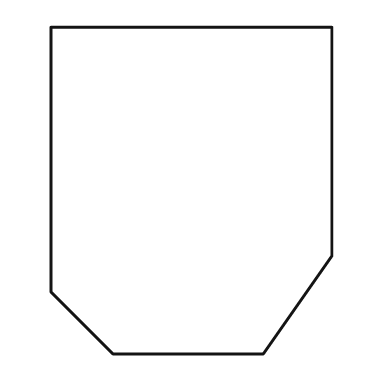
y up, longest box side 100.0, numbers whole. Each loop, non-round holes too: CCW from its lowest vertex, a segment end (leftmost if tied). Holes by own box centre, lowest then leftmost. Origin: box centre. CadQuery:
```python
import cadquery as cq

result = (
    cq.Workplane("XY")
    .moveTo(-24.0, -50.0)
    .lineTo(22.0, -50.0)
    .lineTo(43.0, -20.0)
    .lineTo(43.0, 50.0)
    .lineTo(-43.0, 50.0)
    .lineTo(-43.0, -31.0)
    .close()
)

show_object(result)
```